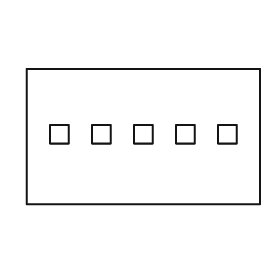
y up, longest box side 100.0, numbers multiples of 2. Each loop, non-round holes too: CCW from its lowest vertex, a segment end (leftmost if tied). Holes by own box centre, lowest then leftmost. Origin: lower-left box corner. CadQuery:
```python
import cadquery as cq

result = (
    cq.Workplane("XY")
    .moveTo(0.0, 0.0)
    .lineTo(100.0, 0.0)
    .lineTo(100.0, 58.0)
    .lineTo(0.0, 58.0)
    .close()
    .moveTo(10.0, 26.0)
    .lineTo(18.0, 26.0)
    .lineTo(18.0, 34.0)
    .lineTo(10.0, 34.0)
    .close()
    .moveTo(28.0, 26.0)
    .lineTo(36.0, 26.0)
    .lineTo(36.0, 34.0)
    .lineTo(28.0, 34.0)
    .close()
    .moveTo(46.0, 26.0)
    .lineTo(54.0, 26.0)
    .lineTo(54.0, 34.0)
    .lineTo(46.0, 34.0)
    .close()
    .moveTo(64.0, 26.0)
    .lineTo(72.0, 26.0)
    .lineTo(72.0, 34.0)
    .lineTo(64.0, 34.0)
    .close()
    .moveTo(82.0, 26.0)
    .lineTo(90.0, 26.0)
    .lineTo(90.0, 34.0)
    .lineTo(82.0, 34.0)
    .close()
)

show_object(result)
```